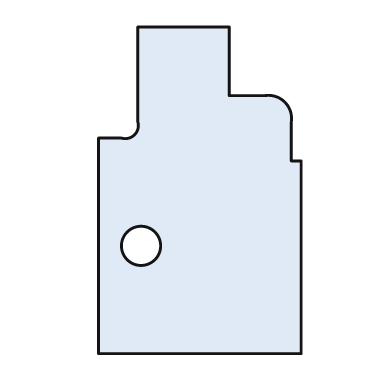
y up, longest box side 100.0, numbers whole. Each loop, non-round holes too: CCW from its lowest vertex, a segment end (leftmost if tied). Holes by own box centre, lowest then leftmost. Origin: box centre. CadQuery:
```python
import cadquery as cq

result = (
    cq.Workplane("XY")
    .moveTo(-31.0, -50.0)
    .lineTo(31.0, -50.0)
    .lineTo(31.0, 9.0)
    .lineTo(28.0, 9.0)
    .lineTo(28.0, 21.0)
    .threePointArc((26.0, 27.0), (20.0, 29.0))
    .lineTo(9.0, 29.0)
    .lineTo(9.0, 50.0)
    .lineTo(-19.0, 50.0)
    .lineTo(-19.0, 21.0)
    .threePointArc((-20.0, 17.0), (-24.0, 16.0))
    .lineTo(-31.0, 16.0)
    .close()
    .moveTo(-18.0, -17.0)
    .circle(6.0)
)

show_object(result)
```